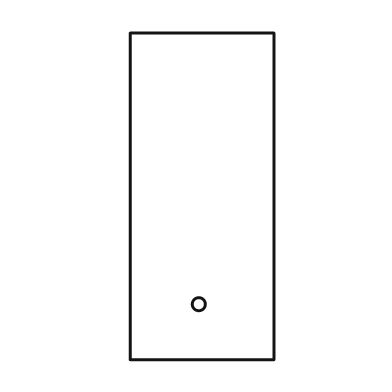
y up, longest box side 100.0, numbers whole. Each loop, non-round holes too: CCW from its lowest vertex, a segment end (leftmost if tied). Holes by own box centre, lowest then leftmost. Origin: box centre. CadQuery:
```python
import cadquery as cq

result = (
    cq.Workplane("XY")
    .moveTo(-22.0, -50.0)
    .lineTo(22.0, -50.0)
    .lineTo(22.0, 50.0)
    .lineTo(-22.0, 50.0)
    .close()
    .moveTo(-1.0, -33.0)
    .circle(2.0)
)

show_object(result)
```